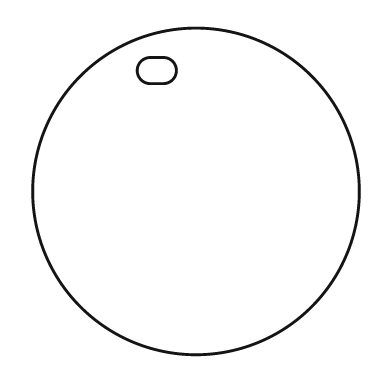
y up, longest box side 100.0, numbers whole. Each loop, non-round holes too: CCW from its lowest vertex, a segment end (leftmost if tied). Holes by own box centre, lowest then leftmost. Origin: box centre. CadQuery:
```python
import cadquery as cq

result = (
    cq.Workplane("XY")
    .moveTo(0.0, 0.0)
    .circle(50.0)
    .moveTo(-14.0, 33.0)
    .lineTo(-10.0, 33.0)
    .threePointArc((-6.0, 37.0), (-10.0, 41.0))
    .lineTo(-14.0, 41.0)
    .threePointArc((-18.0, 37.0), (-14.0, 33.0))
    .close()
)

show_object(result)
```